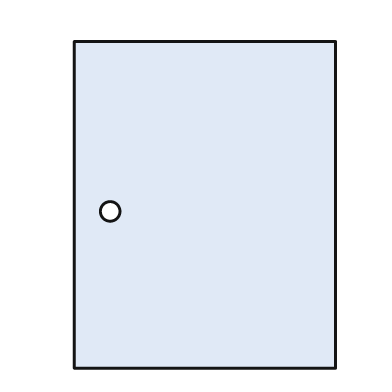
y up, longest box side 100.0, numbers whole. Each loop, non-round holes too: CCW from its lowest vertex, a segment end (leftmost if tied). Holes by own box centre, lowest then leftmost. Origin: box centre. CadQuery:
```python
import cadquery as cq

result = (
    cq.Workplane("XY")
    .moveTo(-40.0, -50.0)
    .lineTo(40.0, -50.0)
    .lineTo(40.0, 50.0)
    .lineTo(-40.0, 50.0)
    .close()
    .moveTo(-29.0, -2.0)
    .circle(3.0)
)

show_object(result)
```